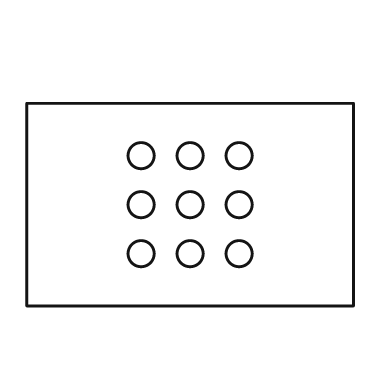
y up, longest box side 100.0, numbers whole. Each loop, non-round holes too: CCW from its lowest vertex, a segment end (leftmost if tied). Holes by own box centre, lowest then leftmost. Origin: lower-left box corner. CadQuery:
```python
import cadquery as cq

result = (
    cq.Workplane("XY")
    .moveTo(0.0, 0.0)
    .lineTo(100.0, 0.0)
    .lineTo(100.0, 62.0)
    .lineTo(0.0, 62.0)
    .close()
    .moveTo(35.0, 16.0)
    .circle(4.0)
    .moveTo(50.0, 16.0)
    .circle(4.0)
    .moveTo(65.0, 16.0)
    .circle(4.0)
    .moveTo(35.0, 31.0)
    .circle(4.0)
    .moveTo(50.0, 31.0)
    .circle(4.0)
    .moveTo(65.0, 31.0)
    .circle(4.0)
    .moveTo(35.0, 46.0)
    .circle(4.0)
    .moveTo(50.0, 46.0)
    .circle(4.0)
    .moveTo(65.0, 46.0)
    .circle(4.0)
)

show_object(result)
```